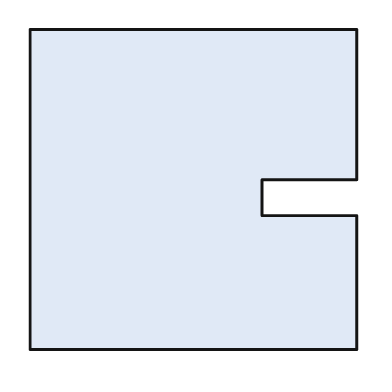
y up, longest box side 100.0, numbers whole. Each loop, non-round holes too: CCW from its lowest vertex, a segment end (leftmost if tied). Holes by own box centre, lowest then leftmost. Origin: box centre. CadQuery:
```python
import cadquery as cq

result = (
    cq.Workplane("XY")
    .moveTo(-50.0, -49.0)
    .lineTo(50.0, -49.0)
    .lineTo(50.0, -8.0)
    .lineTo(21.0, -8.0)
    .lineTo(21.0, 3.0)
    .lineTo(50.0, 3.0)
    .lineTo(50.0, 49.0)
    .lineTo(-50.0, 49.0)
    .close()
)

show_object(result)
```